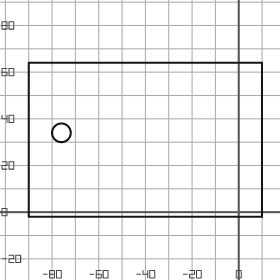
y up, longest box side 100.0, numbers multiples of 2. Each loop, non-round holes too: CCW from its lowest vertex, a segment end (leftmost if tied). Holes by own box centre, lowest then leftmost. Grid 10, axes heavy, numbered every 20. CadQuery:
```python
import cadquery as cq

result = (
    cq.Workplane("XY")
    .moveTo(-90.0, -2.0)
    .lineTo(10.0, -2.0)
    .lineTo(10.0, 64.0)
    .lineTo(-90.0, 64.0)
    .close()
    .moveTo(-76.0, 34.0)
    .circle(4.0)
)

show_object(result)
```